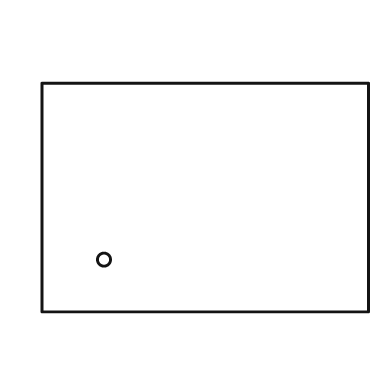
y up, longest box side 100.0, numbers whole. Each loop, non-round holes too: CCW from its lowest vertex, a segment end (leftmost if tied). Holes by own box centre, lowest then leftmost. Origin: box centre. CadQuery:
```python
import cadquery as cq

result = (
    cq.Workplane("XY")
    .moveTo(-50.0, -35.0)
    .lineTo(50.0, -35.0)
    .lineTo(50.0, 35.0)
    .lineTo(-50.0, 35.0)
    .close()
    .moveTo(-31.0, -19.0)
    .circle(2.0)
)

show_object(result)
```